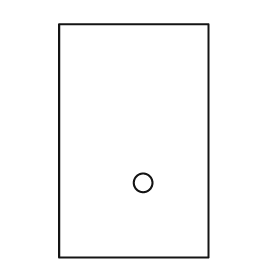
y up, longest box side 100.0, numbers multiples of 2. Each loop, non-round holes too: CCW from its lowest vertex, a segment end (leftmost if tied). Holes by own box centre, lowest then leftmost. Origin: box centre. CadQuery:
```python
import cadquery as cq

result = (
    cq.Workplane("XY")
    .moveTo(-32.0, -50.0)
    .lineTo(32.0, -50.0)
    .lineTo(32.0, 50.0)
    .lineTo(-32.0, 50.0)
    .close()
    .moveTo(4.0, -18.0)
    .circle(4.0)
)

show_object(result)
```